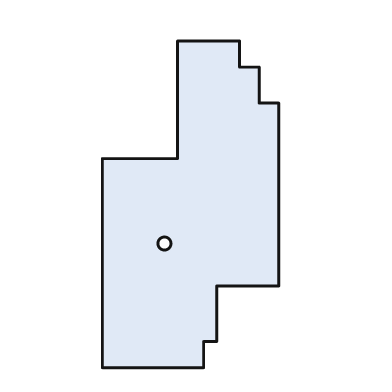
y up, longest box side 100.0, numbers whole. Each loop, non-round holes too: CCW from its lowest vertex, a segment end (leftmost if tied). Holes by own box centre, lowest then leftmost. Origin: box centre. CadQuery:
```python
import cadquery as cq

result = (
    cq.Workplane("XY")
    .moveTo(-27.0, -50.0)
    .lineTo(4.0, -50.0)
    .lineTo(4.0, -42.0)
    .lineTo(8.0, -42.0)
    .lineTo(8.0, -25.0)
    .lineTo(27.0, -25.0)
    .lineTo(27.0, 31.0)
    .lineTo(21.0, 31.0)
    .lineTo(21.0, 42.0)
    .lineTo(15.0, 42.0)
    .lineTo(15.0, 50.0)
    .lineTo(-4.0, 50.0)
    .lineTo(-4.0, 14.0)
    .lineTo(-27.0, 14.0)
    .close()
    .moveTo(-8.0, -12.0)
    .circle(2.0)
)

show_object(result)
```